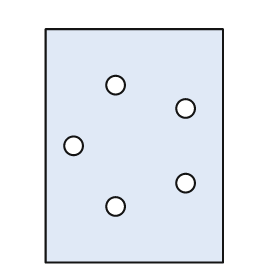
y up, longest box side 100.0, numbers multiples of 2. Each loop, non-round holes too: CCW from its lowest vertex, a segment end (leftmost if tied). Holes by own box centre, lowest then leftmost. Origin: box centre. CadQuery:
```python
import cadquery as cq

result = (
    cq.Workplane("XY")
    .moveTo(-38.0, -50.0)
    .lineTo(38.0, -50.0)
    .lineTo(38.0, 50.0)
    .lineTo(-38.0, 50.0)
    .close()
    .moveTo(-8.0, -26.0)
    .circle(4.0)
    .moveTo(22.0, -16.0)
    .circle(4.0)
    .moveTo(-26.0, 0.0)
    .circle(4.0)
    .moveTo(22.0, 16.0)
    .circle(4.0)
    .moveTo(-8.0, 26.0)
    .circle(4.0)
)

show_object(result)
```